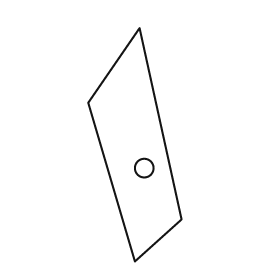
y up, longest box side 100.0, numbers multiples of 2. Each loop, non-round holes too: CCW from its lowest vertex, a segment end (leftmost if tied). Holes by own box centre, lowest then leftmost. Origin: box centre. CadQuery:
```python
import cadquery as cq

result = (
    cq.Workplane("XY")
    .moveTo(0.0, -50.0)
    .lineTo(20.0, -32.0)
    .lineTo(2.0, 50.0)
    .lineTo(-20.0, 18.0)
    .close()
    .moveTo(4.0, -10.0)
    .circle(4.0)
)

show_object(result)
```